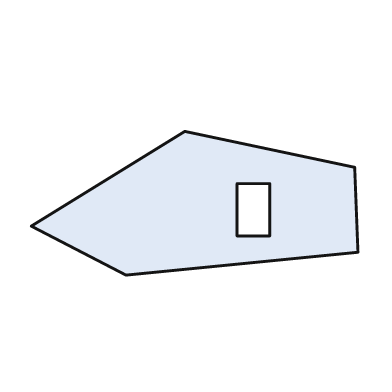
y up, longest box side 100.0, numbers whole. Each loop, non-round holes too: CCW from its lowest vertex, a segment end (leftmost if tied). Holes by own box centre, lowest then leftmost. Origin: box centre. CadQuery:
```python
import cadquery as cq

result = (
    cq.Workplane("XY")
    .moveTo(-21.0, -22.0)
    .lineTo(50.0, -15.0)
    .lineTo(49.0, 11.0)
    .lineTo(-3.0, 22.0)
    .lineTo(-50.0, -7.0)
    .close()
    .moveTo(13.0, -10.0)
    .lineTo(23.0, -10.0)
    .lineTo(23.0, 6.0)
    .lineTo(13.0, 6.0)
    .close()
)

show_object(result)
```